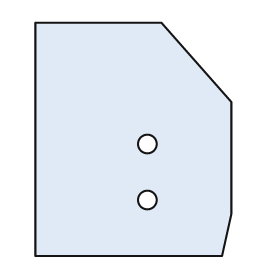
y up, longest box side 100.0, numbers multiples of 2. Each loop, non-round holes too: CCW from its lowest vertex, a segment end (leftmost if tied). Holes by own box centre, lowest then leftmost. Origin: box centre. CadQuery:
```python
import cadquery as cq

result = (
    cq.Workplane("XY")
    .moveTo(-42.0, -50.0)
    .lineTo(38.0, -50.0)
    .lineTo(42.0, -32.0)
    .lineTo(42.0, 16.0)
    .lineTo(12.0, 50.0)
    .lineTo(-42.0, 50.0)
    .close()
    .moveTo(6.0, -26.0)
    .circle(4.0)
    .moveTo(6.0, -2.0)
    .circle(4.0)
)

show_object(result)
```